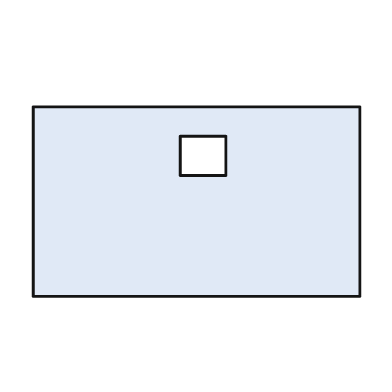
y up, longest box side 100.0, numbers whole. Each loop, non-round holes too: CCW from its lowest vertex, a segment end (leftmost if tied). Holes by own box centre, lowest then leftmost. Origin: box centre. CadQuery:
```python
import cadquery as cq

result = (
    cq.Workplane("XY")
    .moveTo(-50.0, -29.0)
    .lineTo(50.0, -29.0)
    .lineTo(50.0, 29.0)
    .lineTo(-50.0, 29.0)
    .close()
    .moveTo(-5.0, 8.0)
    .lineTo(9.0, 8.0)
    .lineTo(9.0, 20.0)
    .lineTo(-5.0, 20.0)
    .close()
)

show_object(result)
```